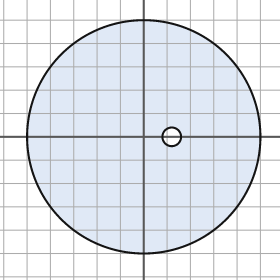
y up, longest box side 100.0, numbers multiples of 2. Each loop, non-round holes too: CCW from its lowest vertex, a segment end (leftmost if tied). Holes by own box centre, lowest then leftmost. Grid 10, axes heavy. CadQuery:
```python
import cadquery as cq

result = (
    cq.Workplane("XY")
    .moveTo(0.0, 0.0)
    .circle(50.0)
    .moveTo(12.0, 0.0)
    .circle(4.0)
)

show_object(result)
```